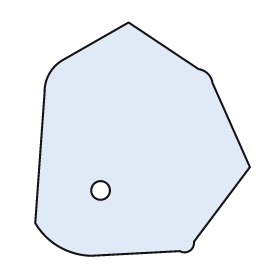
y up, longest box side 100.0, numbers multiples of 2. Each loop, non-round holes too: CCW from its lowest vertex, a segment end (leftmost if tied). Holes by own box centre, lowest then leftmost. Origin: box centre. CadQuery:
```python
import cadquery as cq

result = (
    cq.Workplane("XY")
    .moveTo(-22.0, -50.0)
    .lineTo(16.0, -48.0)
    .threePointArc((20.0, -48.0), (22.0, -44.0))
    .lineTo(46.0, -12.0)
    .lineTo(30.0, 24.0)
    .threePointArc((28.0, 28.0), (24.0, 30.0))
    .lineTo(-6.0, 50.0)
    .lineTo(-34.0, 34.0)
    .threePointArc((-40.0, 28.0), (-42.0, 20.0))
    .lineTo(-46.0, -36.0)
    .threePointArc((-36.0, -46.0), (-22.0, -50.0))
    .close()
    .moveTo(-18.0, -22.0)
    .circle(4.0)
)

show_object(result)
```